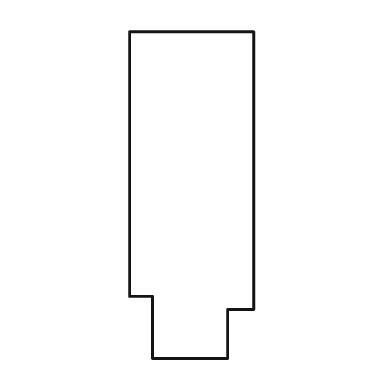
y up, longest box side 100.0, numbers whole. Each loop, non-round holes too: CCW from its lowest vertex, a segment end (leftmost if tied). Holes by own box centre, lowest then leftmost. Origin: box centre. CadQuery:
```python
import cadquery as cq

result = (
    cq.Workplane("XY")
    .moveTo(-12.0, -50.0)
    .lineTo(11.0, -50.0)
    .lineTo(11.0, -35.0)
    .lineTo(19.0, -35.0)
    .lineTo(19.0, 50.0)
    .lineTo(-19.0, 50.0)
    .lineTo(-19.0, -31.0)
    .lineTo(-12.0, -31.0)
    .close()
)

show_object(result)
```